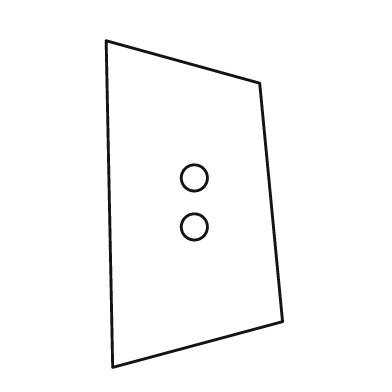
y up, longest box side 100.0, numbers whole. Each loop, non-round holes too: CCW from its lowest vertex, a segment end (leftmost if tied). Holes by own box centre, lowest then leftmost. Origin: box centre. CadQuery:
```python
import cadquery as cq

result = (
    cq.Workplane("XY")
    .moveTo(-25.0, -50.0)
    .lineTo(27.0, -36.0)
    .lineTo(20.0, 37.0)
    .lineTo(-27.0, 50.0)
    .close()
    .moveTo(0.0, -7.0)
    .circle(4.0)
    .moveTo(0.0, 8.0)
    .circle(4.0)
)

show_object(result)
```